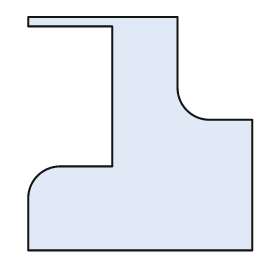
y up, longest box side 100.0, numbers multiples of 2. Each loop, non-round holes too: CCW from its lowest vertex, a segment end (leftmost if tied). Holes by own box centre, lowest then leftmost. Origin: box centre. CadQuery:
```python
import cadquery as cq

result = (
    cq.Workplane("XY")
    .moveTo(-48.0, -50.0)
    .lineTo(48.0, -50.0)
    .lineTo(48.0, 6.0)
    .lineTo(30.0, 6.0)
    .threePointArc((20.0, 10.0), (16.0, 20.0))
    .lineTo(16.0, 50.0)
    .lineTo(-48.0, 50.0)
    .lineTo(-48.0, 46.0)
    .lineTo(-12.0, 46.0)
    .lineTo(-12.0, -14.0)
    .lineTo(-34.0, -14.0)
    .threePointArc((-44.0, -18.0), (-48.0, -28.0))
    .close()
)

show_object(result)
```